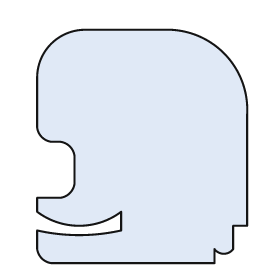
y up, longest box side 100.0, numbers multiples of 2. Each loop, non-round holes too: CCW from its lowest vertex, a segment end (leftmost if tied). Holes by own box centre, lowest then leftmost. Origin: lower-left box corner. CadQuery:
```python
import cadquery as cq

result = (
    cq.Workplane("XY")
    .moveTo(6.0, 0.0)
    .lineTo(76.0, 0.0)
    .lineTo(76.0, 6.0)
    .threePointArc((80.0, 4.0), (84.0, 6.0))
    .lineTo(84.0, 16.0)
    .lineTo(90.0, 16.0)
    .lineTo(90.0, 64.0)
    .threePointArc((80.0, 90.0), (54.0, 100.0))
    .lineTo(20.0, 100.0)
    .threePointArc((6.0, 94.0), (0.0, 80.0))
    .lineTo(0.0, 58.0)
    .threePointArc((2.0, 54.0), (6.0, 52.0))
    .lineTo(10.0, 52.0)
    .threePointArc((14.0, 50.0), (16.0, 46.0))
    .lineTo(16.0, 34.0)
    .threePointArc((14.0, 30.0), (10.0, 28.0))
    .lineTo(0.0, 28.0)
    .lineTo(0.0, 22.0)
    .threePointArc((18.0, 16.0), (36.0, 22.0))
    .lineTo(36.0, 14.0)
    .threePointArc((18.0, 12.0), (0.0, 14.0))
    .lineTo(0.0, 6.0)
    .threePointArc((2.0, 2.0), (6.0, 0.0))
    .close()
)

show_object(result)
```